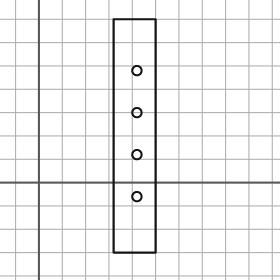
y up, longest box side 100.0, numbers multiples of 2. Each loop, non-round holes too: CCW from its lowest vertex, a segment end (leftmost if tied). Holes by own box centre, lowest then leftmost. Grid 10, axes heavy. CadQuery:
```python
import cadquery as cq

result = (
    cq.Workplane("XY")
    .moveTo(32.0, -30.0)
    .lineTo(50.0, -30.0)
    .lineTo(50.0, 70.0)
    .lineTo(32.0, 70.0)
    .close()
    .moveTo(42.0, -6.0)
    .circle(2.0)
    .moveTo(42.0, 12.0)
    .circle(2.0)
    .moveTo(42.0, 30.0)
    .circle(2.0)
    .moveTo(42.0, 48.0)
    .circle(2.0)
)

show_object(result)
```